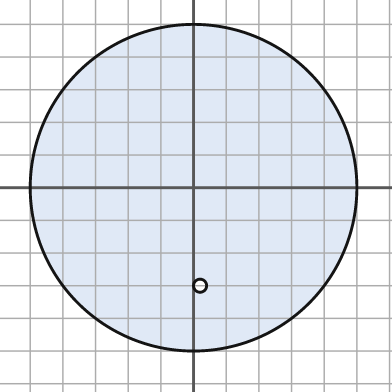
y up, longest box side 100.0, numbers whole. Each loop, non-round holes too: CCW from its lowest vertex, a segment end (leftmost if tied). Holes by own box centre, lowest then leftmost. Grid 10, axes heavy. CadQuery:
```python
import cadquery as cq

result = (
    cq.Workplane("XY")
    .moveTo(0.0, 0.0)
    .circle(50.0)
    .moveTo(2.0, -30.0)
    .circle(2.0)
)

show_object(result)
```